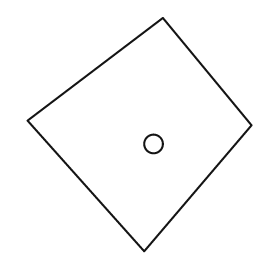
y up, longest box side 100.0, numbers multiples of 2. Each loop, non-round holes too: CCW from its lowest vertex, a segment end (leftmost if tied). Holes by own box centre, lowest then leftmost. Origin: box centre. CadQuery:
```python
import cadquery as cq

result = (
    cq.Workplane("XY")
    .moveTo(2.0, -50.0)
    .lineTo(48.0, 4.0)
    .lineTo(10.0, 50.0)
    .lineTo(-48.0, 6.0)
    .close()
    .moveTo(6.0, -4.0)
    .circle(4.0)
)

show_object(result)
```